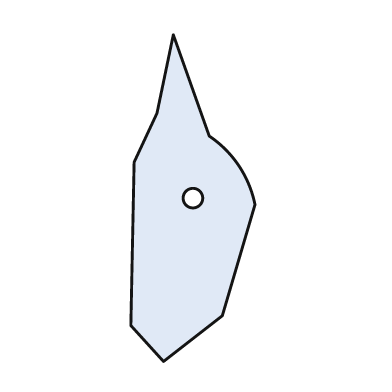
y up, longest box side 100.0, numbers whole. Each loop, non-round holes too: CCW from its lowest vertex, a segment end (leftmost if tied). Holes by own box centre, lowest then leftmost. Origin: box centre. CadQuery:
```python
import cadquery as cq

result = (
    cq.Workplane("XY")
    .moveTo(-9.0, -50.0)
    .lineTo(9.0, -36.0)
    .lineTo(19.0, -2.0)
    .threePointArc((14.0, 10.0), (5.0, 19.0))
    .lineTo(-6.0, 50.0)
    .lineTo(-11.0, 26.0)
    .lineTo(-18.0, 11.0)
    .lineTo(-19.0, -39.0)
    .close()
    .moveTo(0.0, 0.0)
    .circle(3.0)
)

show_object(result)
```